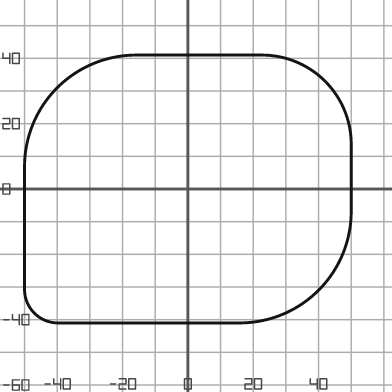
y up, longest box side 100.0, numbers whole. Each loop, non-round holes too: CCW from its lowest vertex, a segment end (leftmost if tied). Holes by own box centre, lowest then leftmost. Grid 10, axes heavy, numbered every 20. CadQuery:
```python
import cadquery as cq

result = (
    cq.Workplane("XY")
    .moveTo(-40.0, -41.0)
    .lineTo(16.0, -41.0)
    .threePointArc((40.0, -31.0), (50.0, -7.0))
    .lineTo(50.0, 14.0)
    .threePointArc((42.0, 33.0), (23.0, 41.0))
    .lineTo(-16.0, 41.0)
    .threePointArc((-40.0, 31.0), (-50.0, 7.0))
    .lineTo(-50.0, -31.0)
    .threePointArc((-47.0, -38.0), (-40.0, -41.0))
    .close()
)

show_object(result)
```